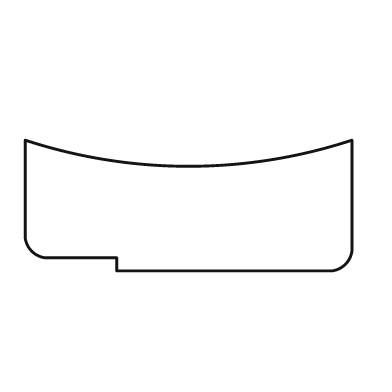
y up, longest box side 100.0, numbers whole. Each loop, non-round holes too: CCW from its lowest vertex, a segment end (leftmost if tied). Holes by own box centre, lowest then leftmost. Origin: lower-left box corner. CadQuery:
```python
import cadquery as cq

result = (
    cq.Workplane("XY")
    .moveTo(28.0, 0.0)
    .lineTo(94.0, 0.0)
    .threePointArc((98.0, 2.0), (100.0, 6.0))
    .lineTo(100.0, 40.0)
    .threePointArc((50.0, 32.0), (0.0, 40.0))
    .lineTo(0.0, 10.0)
    .threePointArc((2.0, 6.0), (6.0, 4.0))
    .lineTo(28.0, 4.0)
    .close()
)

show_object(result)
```